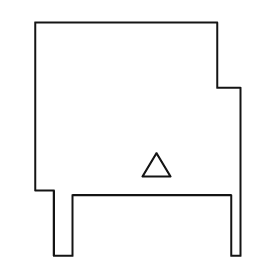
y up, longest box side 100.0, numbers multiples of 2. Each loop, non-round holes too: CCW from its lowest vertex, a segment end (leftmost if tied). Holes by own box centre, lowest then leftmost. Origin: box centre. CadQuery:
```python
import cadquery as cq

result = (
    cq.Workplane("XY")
    .moveTo(-36.0, -50.0)
    .lineTo(-28.0, -50.0)
    .lineTo(-28.0, -24.0)
    .lineTo(40.0, -24.0)
    .lineTo(40.0, -50.0)
    .lineTo(44.0, -50.0)
    .lineTo(44.0, 22.0)
    .lineTo(34.0, 22.0)
    .lineTo(34.0, 50.0)
    .lineTo(-44.0, 50.0)
    .lineTo(-44.0, -22.0)
    .lineTo(-36.0, -22.0)
    .close()
    .moveTo(2.0, -16.0)
    .lineTo(14.0, -16.0)
    .lineTo(8.0, -6.0)
    .close()
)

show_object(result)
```